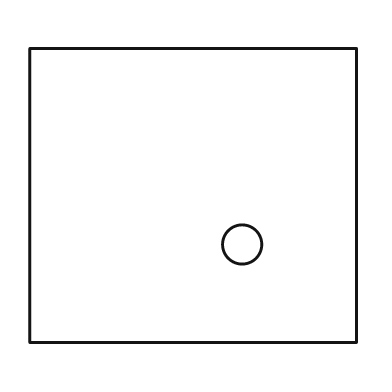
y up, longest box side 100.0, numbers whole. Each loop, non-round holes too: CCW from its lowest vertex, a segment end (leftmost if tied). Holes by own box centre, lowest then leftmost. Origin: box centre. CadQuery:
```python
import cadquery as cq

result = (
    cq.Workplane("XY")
    .moveTo(-50.0, -45.0)
    .lineTo(50.0, -45.0)
    .lineTo(50.0, 45.0)
    .lineTo(-50.0, 45.0)
    .close()
    .moveTo(15.0, -15.0)
    .circle(6.0)
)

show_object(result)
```